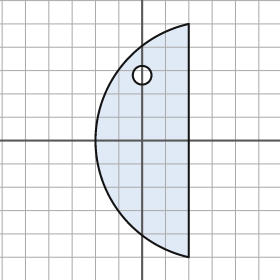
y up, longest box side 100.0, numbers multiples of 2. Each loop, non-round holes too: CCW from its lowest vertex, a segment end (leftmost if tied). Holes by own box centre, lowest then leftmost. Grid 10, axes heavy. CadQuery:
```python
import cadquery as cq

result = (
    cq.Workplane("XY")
    .moveTo(20.0, -50.0)
    .lineTo(20.0, 50.0)
    .threePointArc((-20.0, 0.0), (20.0, -50.0))
    .close()
    .moveTo(0.0, 28.0)
    .circle(4.0)
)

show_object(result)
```